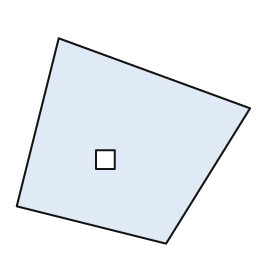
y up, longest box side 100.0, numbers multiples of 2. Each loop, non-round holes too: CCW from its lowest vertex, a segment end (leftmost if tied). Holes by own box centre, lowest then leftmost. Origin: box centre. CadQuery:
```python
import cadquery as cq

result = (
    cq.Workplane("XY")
    .moveTo(14.0, -44.0)
    .lineTo(50.0, 14.0)
    .lineTo(-32.0, 44.0)
    .lineTo(-50.0, -28.0)
    .close()
    .moveTo(-16.0, -12.0)
    .lineTo(-8.0, -12.0)
    .lineTo(-8.0, -4.0)
    .lineTo(-16.0, -4.0)
    .close()
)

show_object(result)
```